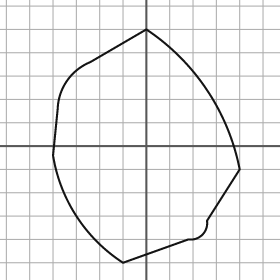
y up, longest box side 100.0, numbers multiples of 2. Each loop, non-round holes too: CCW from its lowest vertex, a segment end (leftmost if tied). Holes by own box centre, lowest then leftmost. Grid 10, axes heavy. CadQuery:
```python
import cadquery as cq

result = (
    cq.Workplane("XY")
    .moveTo(-10.0, -50.0)
    .lineTo(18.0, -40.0)
    .threePointArc((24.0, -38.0), (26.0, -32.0))
    .lineTo(40.0, -10.0)
    .threePointArc((26.0, 24.0), (0.0, 50.0))
    .lineTo(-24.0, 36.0)
    .threePointArc((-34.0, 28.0), (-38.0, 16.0))
    .lineTo(-40.0, -4.0)
    .threePointArc((-30.0, -30.0), (-10.0, -50.0))
    .close()
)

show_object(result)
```